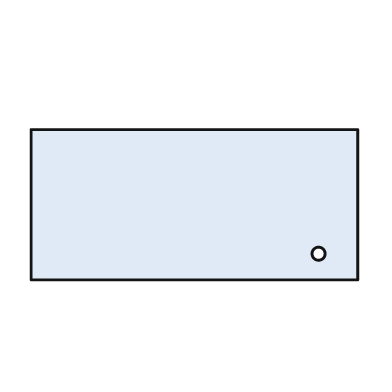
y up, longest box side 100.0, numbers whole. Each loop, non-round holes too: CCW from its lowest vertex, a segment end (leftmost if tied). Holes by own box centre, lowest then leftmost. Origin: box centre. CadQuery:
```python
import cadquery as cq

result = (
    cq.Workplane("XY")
    .moveTo(-50.0, -23.0)
    .lineTo(50.0, -23.0)
    .lineTo(50.0, 23.0)
    .lineTo(-50.0, 23.0)
    .close()
    .moveTo(38.0, -15.0)
    .circle(2.0)
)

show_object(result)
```